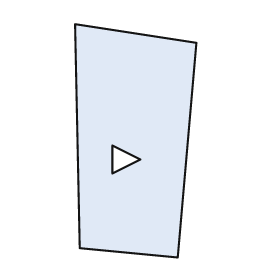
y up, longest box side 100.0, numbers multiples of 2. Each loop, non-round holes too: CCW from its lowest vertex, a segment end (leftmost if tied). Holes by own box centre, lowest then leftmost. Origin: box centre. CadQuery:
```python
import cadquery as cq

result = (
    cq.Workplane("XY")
    .moveTo(18.0, -50.0)
    .lineTo(26.0, 42.0)
    .lineTo(-26.0, 50.0)
    .lineTo(-24.0, -46.0)
    .close()
    .moveTo(-10.0, -14.0)
    .lineTo(2.0, -8.0)
    .lineTo(-10.0, -2.0)
    .close()
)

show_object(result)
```